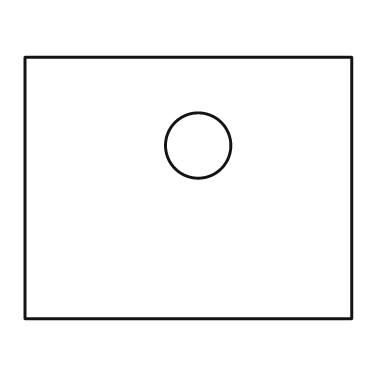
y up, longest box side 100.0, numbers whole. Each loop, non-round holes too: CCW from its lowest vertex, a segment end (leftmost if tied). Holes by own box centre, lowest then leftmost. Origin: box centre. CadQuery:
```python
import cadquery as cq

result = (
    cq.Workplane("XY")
    .moveTo(-50.0, -40.0)
    .lineTo(50.0, -40.0)
    .lineTo(50.0, 40.0)
    .lineTo(-50.0, 40.0)
    .close()
    .moveTo(3.0, 13.0)
    .circle(10.0)
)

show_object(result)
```